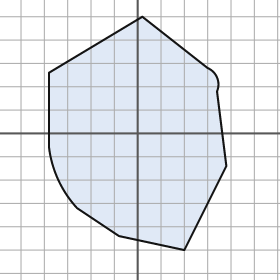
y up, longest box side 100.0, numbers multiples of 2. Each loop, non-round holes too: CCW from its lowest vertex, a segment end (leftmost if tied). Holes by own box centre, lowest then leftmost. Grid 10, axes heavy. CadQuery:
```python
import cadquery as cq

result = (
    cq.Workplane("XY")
    .moveTo(20.0, -50.0)
    .lineTo(38.0, -14.0)
    .lineTo(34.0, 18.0)
    .threePointArc((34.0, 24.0), (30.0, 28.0))
    .lineTo(2.0, 50.0)
    .lineTo(-38.0, 26.0)
    .lineTo(-38.0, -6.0)
    .threePointArc((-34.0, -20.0), (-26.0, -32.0))
    .lineTo(-8.0, -44.0)
    .close()
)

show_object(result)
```